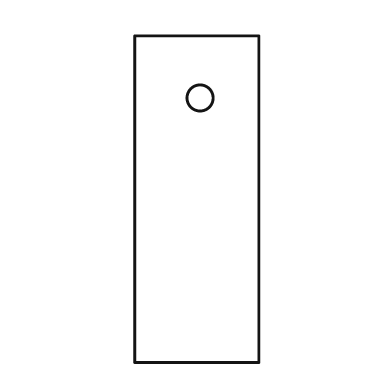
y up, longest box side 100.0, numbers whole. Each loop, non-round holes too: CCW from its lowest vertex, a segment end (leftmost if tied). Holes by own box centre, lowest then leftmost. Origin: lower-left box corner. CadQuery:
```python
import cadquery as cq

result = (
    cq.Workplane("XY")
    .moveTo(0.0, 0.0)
    .lineTo(38.0, 0.0)
    .lineTo(38.0, 100.0)
    .lineTo(0.0, 100.0)
    .close()
    .moveTo(20.0, 81.0)
    .circle(4.0)
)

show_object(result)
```